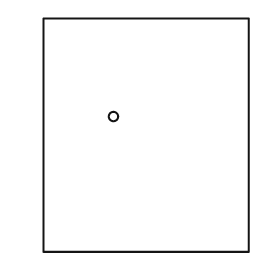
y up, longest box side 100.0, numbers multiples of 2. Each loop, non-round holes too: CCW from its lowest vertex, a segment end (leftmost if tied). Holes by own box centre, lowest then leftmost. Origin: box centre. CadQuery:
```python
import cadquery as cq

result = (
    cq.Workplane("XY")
    .moveTo(-44.0, -50.0)
    .lineTo(44.0, -50.0)
    .lineTo(44.0, 50.0)
    .lineTo(-44.0, 50.0)
    .close()
    .moveTo(-14.0, 8.0)
    .circle(2.0)
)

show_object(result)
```